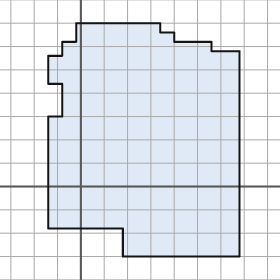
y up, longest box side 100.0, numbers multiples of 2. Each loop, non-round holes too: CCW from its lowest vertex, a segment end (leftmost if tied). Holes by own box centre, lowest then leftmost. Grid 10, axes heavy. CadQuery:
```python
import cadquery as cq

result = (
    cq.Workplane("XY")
    .moveTo(18.0, -30.0)
    .lineTo(68.0, -30.0)
    .lineTo(68.0, 58.0)
    .lineTo(56.0, 58.0)
    .lineTo(56.0, 62.0)
    .lineTo(40.0, 62.0)
    .lineTo(40.0, 66.0)
    .lineTo(34.0, 66.0)
    .lineTo(34.0, 70.0)
    .lineTo(-2.0, 70.0)
    .lineTo(-2.0, 62.0)
    .lineTo(-8.0, 62.0)
    .lineTo(-8.0, 56.0)
    .lineTo(-14.0, 56.0)
    .lineTo(-14.0, 44.0)
    .lineTo(-8.0, 44.0)
    .lineTo(-8.0, 30.0)
    .lineTo(-14.0, 30.0)
    .lineTo(-14.0, -18.0)
    .lineTo(18.0, -18.0)
    .close()
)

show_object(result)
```